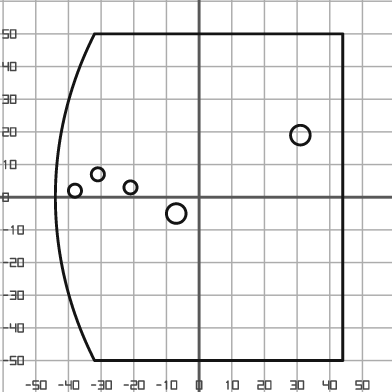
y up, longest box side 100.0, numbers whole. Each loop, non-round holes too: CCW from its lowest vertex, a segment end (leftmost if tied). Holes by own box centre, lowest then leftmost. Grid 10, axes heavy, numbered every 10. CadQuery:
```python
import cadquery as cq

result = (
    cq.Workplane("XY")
    .moveTo(-32.0, -50.0)
    .lineTo(44.0, -50.0)
    .lineTo(44.0, 50.0)
    .lineTo(-32.0, 50.0)
    .threePointArc((-44.0, 0.0), (-32.0, -50.0))
    .close()
    .moveTo(-7.0, -5.0)
    .circle(3.0)
    .moveTo(-38.0, 2.0)
    .circle(2.0)
    .moveTo(-21.0, 3.0)
    .circle(2.0)
    .moveTo(-31.0, 7.0)
    .circle(2.0)
    .moveTo(31.0, 19.0)
    .circle(3.0)
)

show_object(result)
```